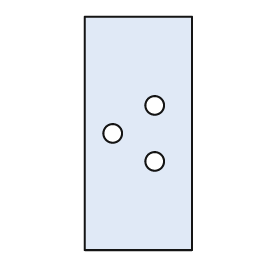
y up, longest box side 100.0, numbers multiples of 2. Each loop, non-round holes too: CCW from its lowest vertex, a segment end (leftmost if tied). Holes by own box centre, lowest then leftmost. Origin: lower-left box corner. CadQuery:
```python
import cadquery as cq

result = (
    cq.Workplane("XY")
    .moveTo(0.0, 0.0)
    .lineTo(46.0, 0.0)
    .lineTo(46.0, 100.0)
    .lineTo(0.0, 100.0)
    .close()
    .moveTo(30.0, 38.0)
    .circle(4.0)
    .moveTo(12.0, 50.0)
    .circle(4.0)
    .moveTo(30.0, 62.0)
    .circle(4.0)
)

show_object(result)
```